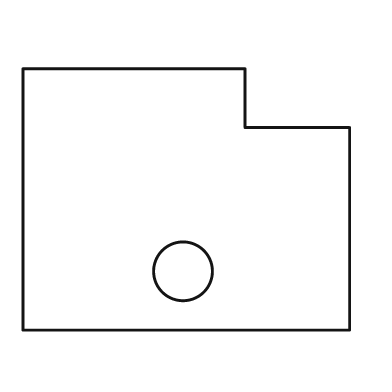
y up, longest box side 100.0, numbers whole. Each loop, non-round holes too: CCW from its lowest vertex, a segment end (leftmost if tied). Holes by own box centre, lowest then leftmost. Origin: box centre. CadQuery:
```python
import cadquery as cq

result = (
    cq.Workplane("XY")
    .moveTo(-50.0, -40.0)
    .lineTo(50.0, -40.0)
    .lineTo(50.0, 22.0)
    .lineTo(18.0, 22.0)
    .lineTo(18.0, 40.0)
    .lineTo(-50.0, 40.0)
    .close()
    .moveTo(-1.0, -22.0)
    .circle(9.0)
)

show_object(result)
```